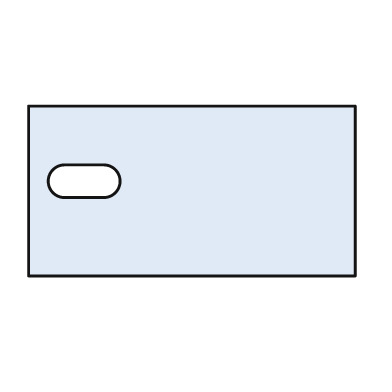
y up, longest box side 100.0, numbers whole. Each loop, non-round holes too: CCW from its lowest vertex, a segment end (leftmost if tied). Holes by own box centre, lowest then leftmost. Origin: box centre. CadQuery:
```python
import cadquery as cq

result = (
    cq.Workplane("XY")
    .moveTo(-50.0, -26.0)
    .lineTo(50.0, -26.0)
    .lineTo(50.0, 26.0)
    .lineTo(-50.0, 26.0)
    .close()
    .moveTo(-39.0, -2.0)
    .lineTo(-27.0, -2.0)
    .threePointArc((-22.0, 3.0), (-27.0, 8.0))
    .lineTo(-39.0, 8.0)
    .threePointArc((-44.0, 3.0), (-39.0, -2.0))
    .close()
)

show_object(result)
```